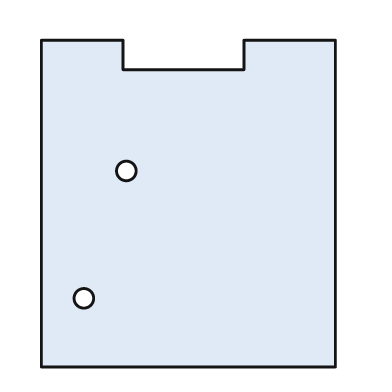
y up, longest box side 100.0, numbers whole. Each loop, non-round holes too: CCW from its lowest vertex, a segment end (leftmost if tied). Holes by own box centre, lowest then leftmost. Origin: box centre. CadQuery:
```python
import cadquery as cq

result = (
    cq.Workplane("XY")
    .moveTo(-45.0, -50.0)
    .lineTo(45.0, -50.0)
    .lineTo(45.0, 50.0)
    .lineTo(17.0, 50.0)
    .lineTo(17.0, 41.0)
    .lineTo(-20.0, 41.0)
    .lineTo(-20.0, 50.0)
    .lineTo(-45.0, 50.0)
    .close()
    .moveTo(-32.0, -29.0)
    .circle(3.0)
    .moveTo(-19.0, 10.0)
    .circle(3.0)
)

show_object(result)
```